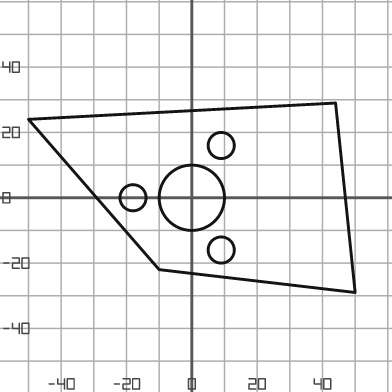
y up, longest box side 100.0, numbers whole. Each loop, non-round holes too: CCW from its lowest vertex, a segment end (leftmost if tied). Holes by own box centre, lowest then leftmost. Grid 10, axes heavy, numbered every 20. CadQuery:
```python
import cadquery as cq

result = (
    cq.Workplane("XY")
    .moveTo(50.0, -29.0)
    .lineTo(44.0, 29.0)
    .lineTo(-50.0, 24.0)
    .lineTo(-10.0, -22.0)
    .close()
    .moveTo(9.0, -16.0)
    .circle(4.0)
    .moveTo(-18.0, 0.0)
    .circle(4.0)
    .moveTo(0.0, 0.0)
    .circle(10.0)
    .moveTo(9.0, 16.0)
    .circle(4.0)
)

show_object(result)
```